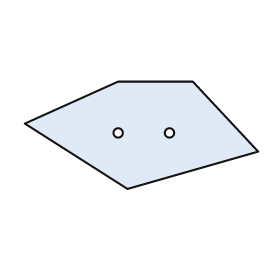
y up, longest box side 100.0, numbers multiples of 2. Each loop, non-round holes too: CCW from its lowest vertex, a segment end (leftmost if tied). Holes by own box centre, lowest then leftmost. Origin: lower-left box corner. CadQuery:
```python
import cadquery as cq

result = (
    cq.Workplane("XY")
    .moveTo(44.0, 0.0)
    .lineTo(100.0, 16.0)
    .lineTo(72.0, 46.0)
    .lineTo(40.0, 46.0)
    .lineTo(0.0, 28.0)
    .close()
    .moveTo(40.0, 24.0)
    .circle(2.0)
    .moveTo(62.0, 24.0)
    .circle(2.0)
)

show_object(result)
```